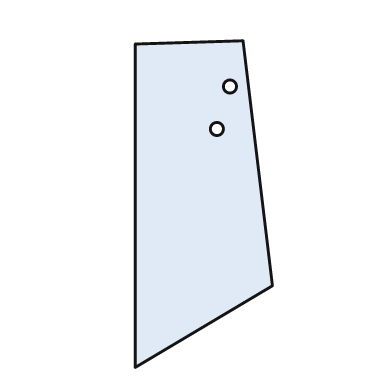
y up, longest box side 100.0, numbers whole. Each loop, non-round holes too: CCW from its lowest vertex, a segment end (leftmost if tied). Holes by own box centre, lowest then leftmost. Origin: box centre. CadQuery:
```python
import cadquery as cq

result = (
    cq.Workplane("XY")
    .moveTo(-21.0, -50.0)
    .lineTo(21.0, -25.0)
    .lineTo(12.0, 50.0)
    .lineTo(-21.0, 49.0)
    .close()
    .moveTo(4.0, 23.0)
    .circle(2.0)
    .moveTo(8.0, 36.0)
    .circle(2.0)
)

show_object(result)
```